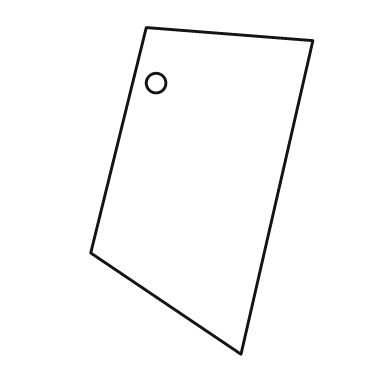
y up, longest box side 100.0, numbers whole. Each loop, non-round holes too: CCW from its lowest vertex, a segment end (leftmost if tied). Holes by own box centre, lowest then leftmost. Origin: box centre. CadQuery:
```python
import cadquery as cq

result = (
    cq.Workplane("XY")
    .moveTo(12.0, -50.0)
    .lineTo(34.0, 46.0)
    .lineTo(-17.0, 50.0)
    .lineTo(-34.0, -19.0)
    .close()
    .moveTo(-14.0, 33.0)
    .circle(3.0)
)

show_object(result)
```